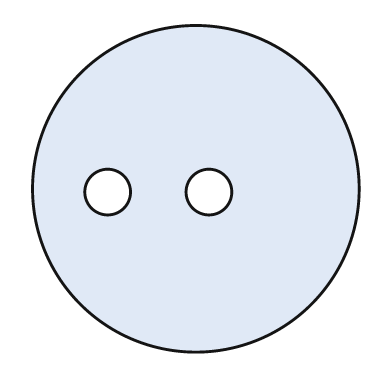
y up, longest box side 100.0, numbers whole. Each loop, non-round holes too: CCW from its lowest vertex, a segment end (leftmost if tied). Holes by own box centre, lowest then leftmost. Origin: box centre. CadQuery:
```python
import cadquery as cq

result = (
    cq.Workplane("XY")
    .moveTo(0.0, 0.0)
    .circle(50.0)
    .moveTo(-27.0, -1.0)
    .circle(7.0)
    .moveTo(4.0, -1.0)
    .circle(7.0)
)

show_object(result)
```